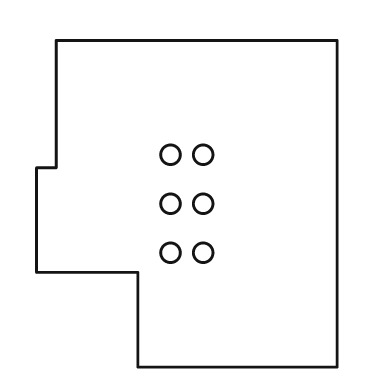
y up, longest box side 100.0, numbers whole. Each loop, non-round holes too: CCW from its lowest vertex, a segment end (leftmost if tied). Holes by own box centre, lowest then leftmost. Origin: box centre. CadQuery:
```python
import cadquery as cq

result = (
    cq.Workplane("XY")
    .moveTo(-15.0, -50.0)
    .lineTo(46.0, -50.0)
    .lineTo(46.0, 50.0)
    .lineTo(-40.0, 50.0)
    .lineTo(-40.0, 11.0)
    .lineTo(-46.0, 11.0)
    .lineTo(-46.0, -21.0)
    .lineTo(-15.0, -21.0)
    .close()
    .moveTo(-5.0, -15.0)
    .circle(3.0)
    .moveTo(5.0, -15.0)
    .circle(3.0)
    .moveTo(-5.0, 0.0)
    .circle(3.0)
    .moveTo(5.0, 0.0)
    .circle(3.0)
    .moveTo(-5.0, 15.0)
    .circle(3.0)
    .moveTo(5.0, 15.0)
    .circle(3.0)
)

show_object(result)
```